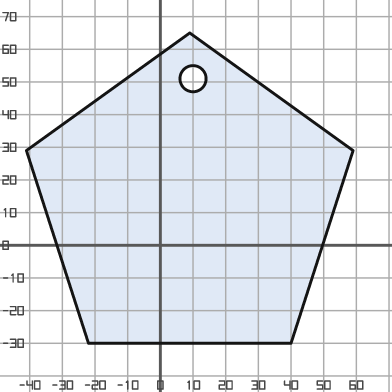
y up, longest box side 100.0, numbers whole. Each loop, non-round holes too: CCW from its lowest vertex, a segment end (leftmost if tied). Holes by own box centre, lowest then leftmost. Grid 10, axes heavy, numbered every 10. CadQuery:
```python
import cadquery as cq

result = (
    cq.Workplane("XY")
    .moveTo(-22.0, -30.0)
    .lineTo(40.0, -30.0)
    .lineTo(59.0, 29.0)
    .lineTo(9.0, 65.0)
    .lineTo(-41.0, 29.0)
    .close()
    .moveTo(10.0, 51.0)
    .circle(4.0)
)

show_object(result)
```